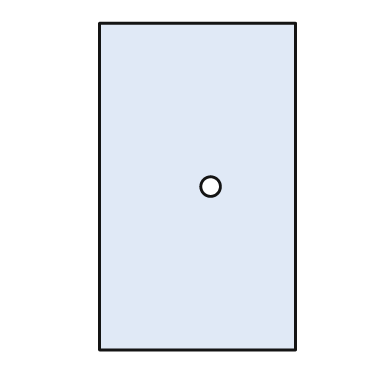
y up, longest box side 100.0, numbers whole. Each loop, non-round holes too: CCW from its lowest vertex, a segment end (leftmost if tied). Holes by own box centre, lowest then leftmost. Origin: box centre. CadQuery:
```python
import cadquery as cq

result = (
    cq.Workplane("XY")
    .moveTo(-30.0, -50.0)
    .lineTo(30.0, -50.0)
    .lineTo(30.0, 50.0)
    .lineTo(-30.0, 50.0)
    .close()
    .moveTo(4.0, 0.0)
    .circle(3.0)
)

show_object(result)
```